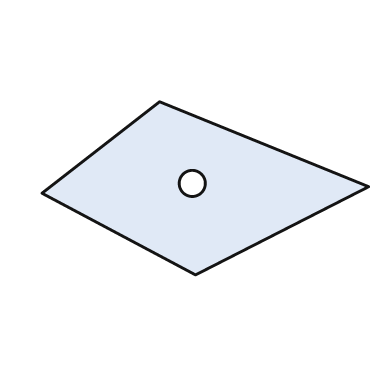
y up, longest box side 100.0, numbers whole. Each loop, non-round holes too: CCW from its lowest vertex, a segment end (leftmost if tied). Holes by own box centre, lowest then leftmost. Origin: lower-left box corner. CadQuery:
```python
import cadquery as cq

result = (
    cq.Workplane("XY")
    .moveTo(47.0, 0.0)
    .lineTo(100.0, 27.0)
    .lineTo(36.0, 53.0)
    .lineTo(0.0, 25.0)
    .close()
    .moveTo(46.0, 28.0)
    .circle(4.0)
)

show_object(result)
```